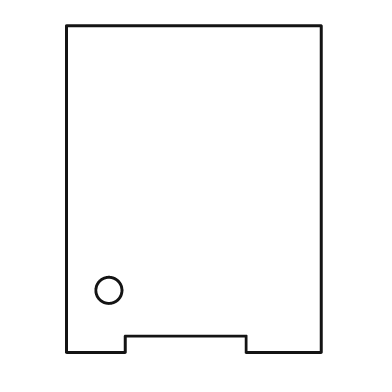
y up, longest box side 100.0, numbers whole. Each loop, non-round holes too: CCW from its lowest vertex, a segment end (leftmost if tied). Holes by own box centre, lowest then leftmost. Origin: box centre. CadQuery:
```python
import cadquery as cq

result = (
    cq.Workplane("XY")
    .moveTo(-39.0, -50.0)
    .lineTo(-21.0, -50.0)
    .lineTo(-21.0, -45.0)
    .lineTo(16.0, -45.0)
    .lineTo(16.0, -50.0)
    .lineTo(39.0, -50.0)
    .lineTo(39.0, 50.0)
    .lineTo(-39.0, 50.0)
    .close()
    .moveTo(-26.0, -31.0)
    .circle(4.0)
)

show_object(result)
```